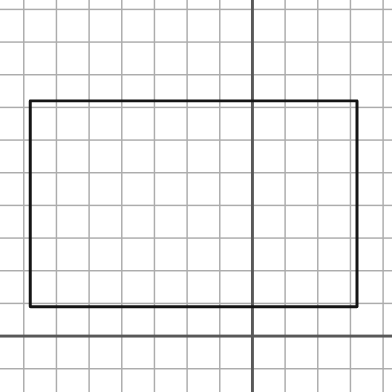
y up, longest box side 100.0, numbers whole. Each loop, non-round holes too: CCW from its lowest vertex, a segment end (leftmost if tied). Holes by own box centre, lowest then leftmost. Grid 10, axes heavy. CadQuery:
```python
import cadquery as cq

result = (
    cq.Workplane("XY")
    .moveTo(-68.0, 9.0)
    .lineTo(32.0, 9.0)
    .lineTo(32.0, 72.0)
    .lineTo(-68.0, 72.0)
    .close()
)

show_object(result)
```